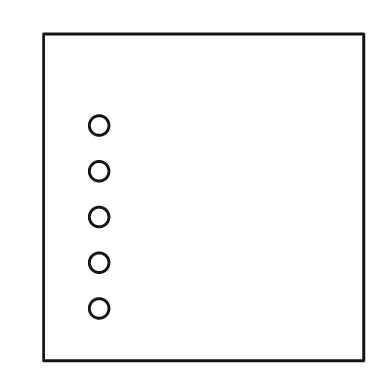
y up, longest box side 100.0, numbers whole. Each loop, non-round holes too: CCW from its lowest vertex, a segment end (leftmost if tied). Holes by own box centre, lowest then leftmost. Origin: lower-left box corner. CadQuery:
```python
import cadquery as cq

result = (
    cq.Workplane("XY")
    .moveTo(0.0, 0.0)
    .lineTo(98.0, 0.0)
    .lineTo(98.0, 100.0)
    .lineTo(0.0, 100.0)
    .close()
    .moveTo(17.0, 16.0)
    .circle(3.0)
    .moveTo(17.0, 30.0)
    .circle(3.0)
    .moveTo(17.0, 44.0)
    .circle(3.0)
    .moveTo(17.0, 58.0)
    .circle(3.0)
    .moveTo(17.0, 72.0)
    .circle(3.0)
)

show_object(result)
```